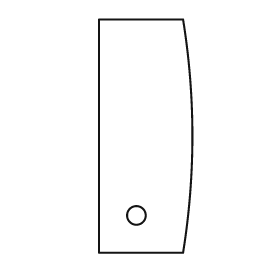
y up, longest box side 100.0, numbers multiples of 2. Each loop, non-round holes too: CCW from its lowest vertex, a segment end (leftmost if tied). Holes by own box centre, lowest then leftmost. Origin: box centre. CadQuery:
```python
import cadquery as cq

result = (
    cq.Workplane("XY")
    .moveTo(-20.0, -50.0)
    .lineTo(16.0, -50.0)
    .threePointArc((20.0, 0.0), (16.0, 50.0))
    .lineTo(-20.0, 50.0)
    .close()
    .moveTo(-4.0, -34.0)
    .circle(4.0)
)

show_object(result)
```